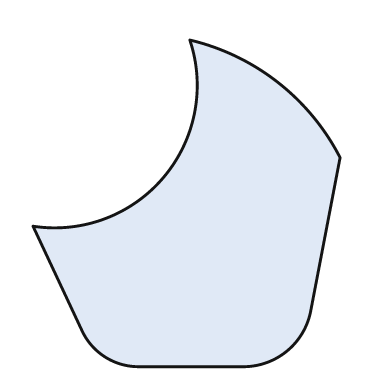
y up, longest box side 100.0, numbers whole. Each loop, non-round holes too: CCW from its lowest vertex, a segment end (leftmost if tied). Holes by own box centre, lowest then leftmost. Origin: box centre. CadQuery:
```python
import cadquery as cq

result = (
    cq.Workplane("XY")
    .moveTo(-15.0, -50.0)
    .lineTo(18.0, -50.0)
    .threePointArc((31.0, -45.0), (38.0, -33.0))
    .lineTo(47.0, 14.0)
    .threePointArc((28.0, 37.0), (1.0, 50.0))
    .threePointArc((-7.0, 8.0), (-47.0, -7.0))
    .lineTo(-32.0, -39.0)
    .threePointArc((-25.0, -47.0), (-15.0, -50.0))
    .close()
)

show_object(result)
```